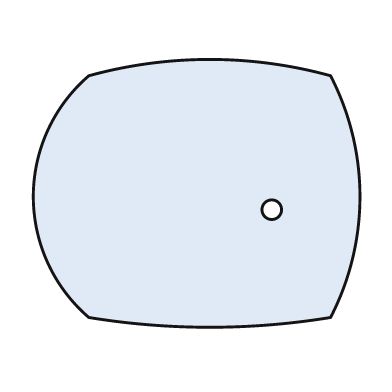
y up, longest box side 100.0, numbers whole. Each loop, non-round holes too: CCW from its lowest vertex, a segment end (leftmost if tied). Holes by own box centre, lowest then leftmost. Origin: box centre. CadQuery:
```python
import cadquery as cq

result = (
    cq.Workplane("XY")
    .moveTo(-33.0, -38.0)
    .threePointArc((4.0, -41.0), (41.0, -38.0))
    .threePointArc((50.0, -1.0), (41.0, 36.0))
    .threePointArc((4.0, 41.0), (-33.0, 36.0))
    .threePointArc((-50.0, -1.0), (-33.0, -38.0))
    .close()
    .moveTo(23.0, -5.0)
    .circle(3.0)
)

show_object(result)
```